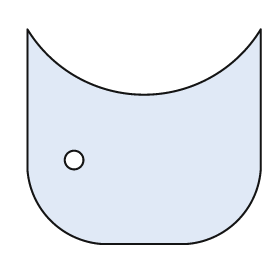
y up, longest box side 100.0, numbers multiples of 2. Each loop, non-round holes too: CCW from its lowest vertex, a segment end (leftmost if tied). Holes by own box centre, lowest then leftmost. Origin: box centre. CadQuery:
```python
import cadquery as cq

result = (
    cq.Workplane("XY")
    .moveTo(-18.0, -46.0)
    .lineTo(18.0, -46.0)
    .threePointArc((40.0, -36.0), (50.0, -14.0))
    .lineTo(50.0, 46.0)
    .threePointArc((0.0, 18.0), (-50.0, 46.0))
    .lineTo(-50.0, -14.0)
    .threePointArc((-40.0, -36.0), (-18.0, -46.0))
    .close()
    .moveTo(-30.0, -10.0)
    .circle(4.0)
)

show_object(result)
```